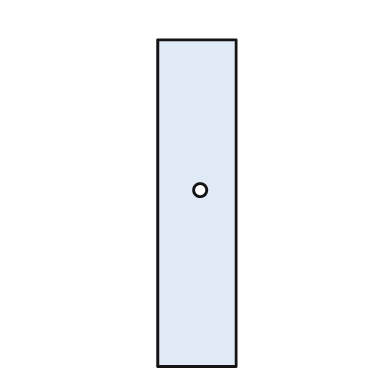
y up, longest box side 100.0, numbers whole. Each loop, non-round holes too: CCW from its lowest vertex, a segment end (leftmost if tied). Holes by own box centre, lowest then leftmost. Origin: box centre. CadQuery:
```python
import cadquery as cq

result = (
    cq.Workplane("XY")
    .moveTo(-12.0, -50.0)
    .lineTo(12.0, -50.0)
    .lineTo(12.0, 50.0)
    .lineTo(-12.0, 50.0)
    .close()
    .moveTo(1.0, 4.0)
    .circle(2.0)
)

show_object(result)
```